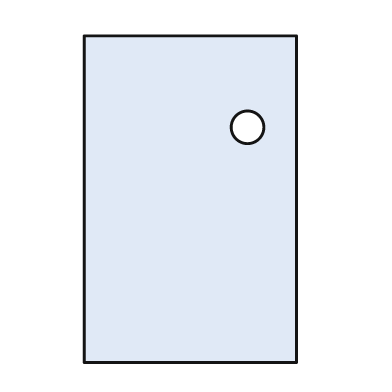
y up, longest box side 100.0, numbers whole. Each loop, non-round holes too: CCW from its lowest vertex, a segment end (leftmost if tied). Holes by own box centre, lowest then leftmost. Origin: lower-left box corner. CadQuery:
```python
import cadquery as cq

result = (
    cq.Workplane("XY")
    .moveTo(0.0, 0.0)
    .lineTo(65.0, 0.0)
    .lineTo(65.0, 100.0)
    .lineTo(0.0, 100.0)
    .close()
    .moveTo(50.0, 72.0)
    .circle(5.0)
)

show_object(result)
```